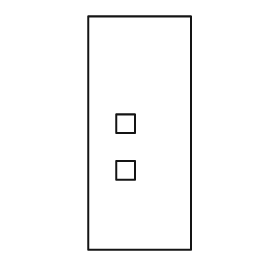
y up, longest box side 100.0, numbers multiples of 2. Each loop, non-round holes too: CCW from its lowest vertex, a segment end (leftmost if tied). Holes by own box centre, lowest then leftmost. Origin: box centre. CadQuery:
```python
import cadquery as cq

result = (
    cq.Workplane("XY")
    .moveTo(-22.0, -50.0)
    .lineTo(22.0, -50.0)
    .lineTo(22.0, 50.0)
    .lineTo(-22.0, 50.0)
    .close()
    .moveTo(-10.0, -20.0)
    .lineTo(-2.0, -20.0)
    .lineTo(-2.0, -12.0)
    .lineTo(-10.0, -12.0)
    .close()
    .moveTo(-10.0, 0.0)
    .lineTo(-2.0, 0.0)
    .lineTo(-2.0, 8.0)
    .lineTo(-10.0, 8.0)
    .close()
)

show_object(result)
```